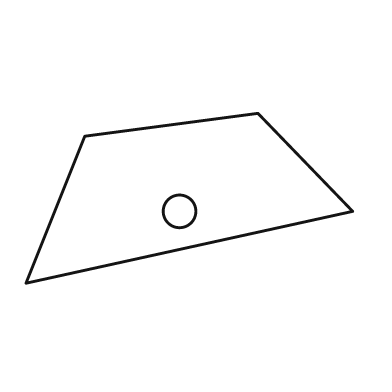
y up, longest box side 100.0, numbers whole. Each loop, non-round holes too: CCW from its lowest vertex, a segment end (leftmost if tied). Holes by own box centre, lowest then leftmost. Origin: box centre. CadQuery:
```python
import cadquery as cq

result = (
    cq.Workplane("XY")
    .moveTo(-50.0, -26.0)
    .lineTo(50.0, -4.0)
    .lineTo(21.0, 26.0)
    .lineTo(-32.0, 19.0)
    .close()
    .moveTo(-3.0, -4.0)
    .circle(5.0)
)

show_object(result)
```